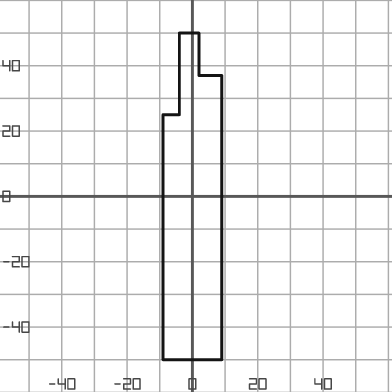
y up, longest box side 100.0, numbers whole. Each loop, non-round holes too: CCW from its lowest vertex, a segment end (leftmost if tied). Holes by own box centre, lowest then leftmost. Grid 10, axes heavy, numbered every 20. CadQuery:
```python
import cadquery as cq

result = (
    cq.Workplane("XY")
    .moveTo(-9.0, -50.0)
    .lineTo(9.0, -50.0)
    .lineTo(9.0, 37.0)
    .lineTo(2.0, 37.0)
    .lineTo(2.0, 50.0)
    .lineTo(-4.0, 50.0)
    .lineTo(-4.0, 25.0)
    .lineTo(-9.0, 25.0)
    .close()
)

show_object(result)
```